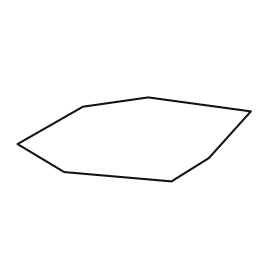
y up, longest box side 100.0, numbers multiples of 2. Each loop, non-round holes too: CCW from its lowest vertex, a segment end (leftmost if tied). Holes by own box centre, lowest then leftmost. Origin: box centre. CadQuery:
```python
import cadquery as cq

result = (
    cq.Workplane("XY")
    .moveTo(16.0, -18.0)
    .lineTo(32.0, -8.0)
    .lineTo(50.0, 12.0)
    .lineTo(6.0, 18.0)
    .lineTo(-22.0, 14.0)
    .lineTo(-50.0, -2.0)
    .lineTo(-30.0, -14.0)
    .close()
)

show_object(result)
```